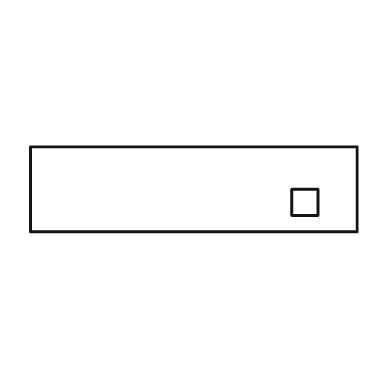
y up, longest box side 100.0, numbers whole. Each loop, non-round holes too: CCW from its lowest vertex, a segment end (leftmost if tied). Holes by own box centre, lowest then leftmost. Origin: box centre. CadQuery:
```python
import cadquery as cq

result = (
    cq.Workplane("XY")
    .moveTo(-50.0, -13.0)
    .lineTo(50.0, -13.0)
    .lineTo(50.0, 13.0)
    .lineTo(-50.0, 13.0)
    .close()
    .moveTo(30.0, -8.0)
    .lineTo(38.0, -8.0)
    .lineTo(38.0, 0.0)
    .lineTo(30.0, 0.0)
    .close()
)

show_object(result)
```